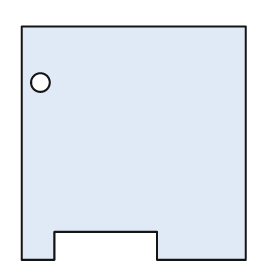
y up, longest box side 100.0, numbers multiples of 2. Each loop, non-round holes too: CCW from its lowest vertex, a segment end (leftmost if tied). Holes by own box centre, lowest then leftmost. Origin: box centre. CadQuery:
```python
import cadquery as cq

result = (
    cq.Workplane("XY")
    .moveTo(-48.0, -50.0)
    .lineTo(-34.0, -50.0)
    .lineTo(-34.0, -38.0)
    .lineTo(10.0, -38.0)
    .lineTo(10.0, -50.0)
    .lineTo(48.0, -50.0)
    .lineTo(48.0, 50.0)
    .lineTo(-48.0, 50.0)
    .close()
    .moveTo(-40.0, 26.0)
    .circle(4.0)
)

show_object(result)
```